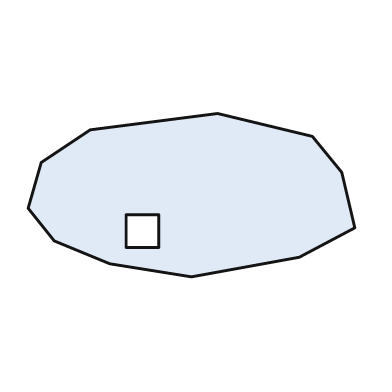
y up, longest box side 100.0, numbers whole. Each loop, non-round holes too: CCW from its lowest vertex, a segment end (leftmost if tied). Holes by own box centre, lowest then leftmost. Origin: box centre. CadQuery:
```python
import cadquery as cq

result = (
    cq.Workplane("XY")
    .moveTo(0.0, -25.0)
    .lineTo(33.0, -19.0)
    .lineTo(50.0, -10.0)
    .lineTo(46.0, 7.0)
    .lineTo(37.0, 18.0)
    .lineTo(8.0, 25.0)
    .lineTo(-31.0, 20.0)
    .lineTo(-46.0, 10.0)
    .lineTo(-50.0, -4.0)
    .lineTo(-42.0, -14.0)
    .lineTo(-25.0, -21.0)
    .close()
    .moveTo(-20.0, -16.0)
    .lineTo(-10.0, -16.0)
    .lineTo(-10.0, -6.0)
    .lineTo(-20.0, -6.0)
    .close()
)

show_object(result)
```